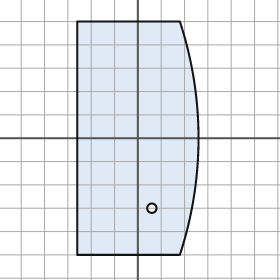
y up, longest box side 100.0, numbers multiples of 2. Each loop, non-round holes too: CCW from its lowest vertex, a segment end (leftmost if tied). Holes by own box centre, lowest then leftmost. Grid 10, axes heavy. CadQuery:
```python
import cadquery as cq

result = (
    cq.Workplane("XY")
    .moveTo(-26.0, -50.0)
    .lineTo(18.0, -50.0)
    .threePointArc((26.0, 0.0), (18.0, 50.0))
    .lineTo(-26.0, 50.0)
    .close()
    .moveTo(6.0, -30.0)
    .circle(2.0)
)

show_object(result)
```